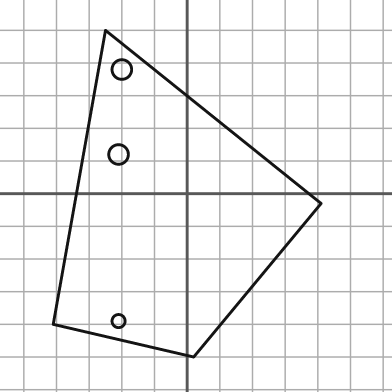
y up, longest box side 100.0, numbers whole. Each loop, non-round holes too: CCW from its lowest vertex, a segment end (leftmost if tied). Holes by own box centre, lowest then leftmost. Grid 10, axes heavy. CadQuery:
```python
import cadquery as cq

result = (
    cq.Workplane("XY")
    .moveTo(2.0, -50.0)
    .lineTo(41.0, -3.0)
    .lineTo(-25.0, 50.0)
    .lineTo(-41.0, -40.0)
    .close()
    .moveTo(-21.0, -39.0)
    .circle(2.0)
    .moveTo(-21.0, 12.0)
    .circle(3.0)
    .moveTo(-20.0, 38.0)
    .circle(3.0)
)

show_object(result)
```